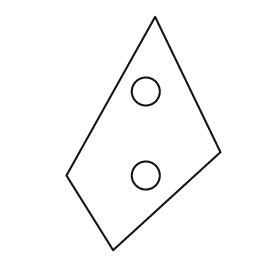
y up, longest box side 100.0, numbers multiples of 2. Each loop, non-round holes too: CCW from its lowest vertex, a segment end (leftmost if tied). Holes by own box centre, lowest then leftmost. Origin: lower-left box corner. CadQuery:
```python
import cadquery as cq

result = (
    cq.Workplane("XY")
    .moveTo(20.0, 0.0)
    .lineTo(66.0, 42.0)
    .lineTo(38.0, 100.0)
    .lineTo(0.0, 32.0)
    .close()
    .moveTo(34.0, 32.0)
    .circle(6.0)
    .moveTo(34.0, 68.0)
    .circle(6.0)
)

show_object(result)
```